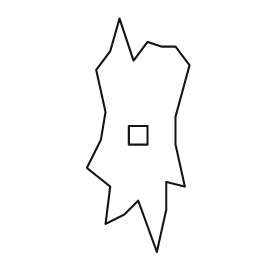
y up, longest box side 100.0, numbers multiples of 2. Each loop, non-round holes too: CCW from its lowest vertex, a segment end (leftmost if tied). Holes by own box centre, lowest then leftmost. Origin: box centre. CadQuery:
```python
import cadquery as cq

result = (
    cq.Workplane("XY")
    .moveTo(8.0, -50.0)
    .lineTo(12.0, -32.0)
    .lineTo(12.0, -20.0)
    .lineTo(20.0, -22.0)
    .lineTo(16.0, -4.0)
    .lineTo(16.0, 8.0)
    .lineTo(22.0, 30.0)
    .lineTo(16.0, 38.0)
    .lineTo(10.0, 38.0)
    .lineTo(4.0, 40.0)
    .lineTo(-2.0, 32.0)
    .lineTo(-8.0, 50.0)
    .lineTo(-12.0, 36.0)
    .lineTo(-18.0, 28.0)
    .lineTo(-14.0, 10.0)
    .lineTo(-16.0, -2.0)
    .lineTo(-22.0, -14.0)
    .lineTo(-12.0, -22.0)
    .lineTo(-14.0, -38.0)
    .lineTo(-6.0, -34.0)
    .lineTo(0.0, -28.0)
    .close()
    .moveTo(-4.0, -4.0)
    .lineTo(4.0, -4.0)
    .lineTo(4.0, 4.0)
    .lineTo(-4.0, 4.0)
    .close()
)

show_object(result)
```